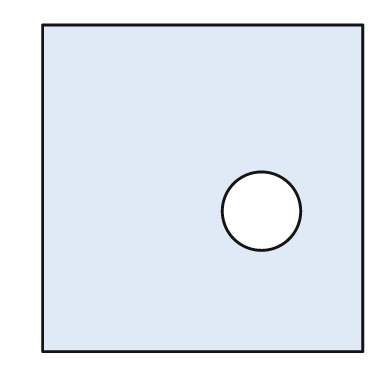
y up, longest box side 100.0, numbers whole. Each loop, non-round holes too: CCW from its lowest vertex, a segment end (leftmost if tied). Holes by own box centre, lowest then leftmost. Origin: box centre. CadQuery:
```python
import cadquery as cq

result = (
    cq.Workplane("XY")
    .moveTo(-49.0, -50.0)
    .lineTo(49.0, -50.0)
    .lineTo(49.0, 50.0)
    .lineTo(-49.0, 50.0)
    .close()
    .moveTo(18.0, -7.0)
    .circle(12.0)
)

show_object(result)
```